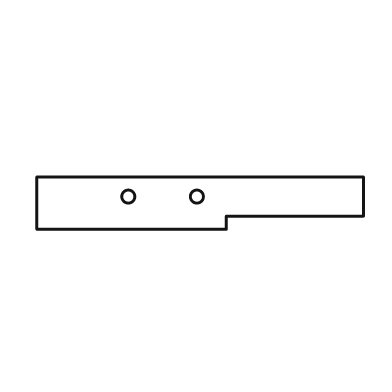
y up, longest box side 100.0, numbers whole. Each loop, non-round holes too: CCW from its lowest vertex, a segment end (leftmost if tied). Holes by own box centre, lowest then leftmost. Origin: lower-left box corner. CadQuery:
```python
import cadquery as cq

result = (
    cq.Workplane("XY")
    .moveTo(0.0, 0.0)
    .lineTo(58.0, 0.0)
    .lineTo(58.0, 4.0)
    .lineTo(100.0, 4.0)
    .lineTo(100.0, 16.0)
    .lineTo(0.0, 16.0)
    .close()
    .moveTo(28.0, 10.0)
    .circle(2.0)
    .moveTo(49.0, 10.0)
    .circle(2.0)
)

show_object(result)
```